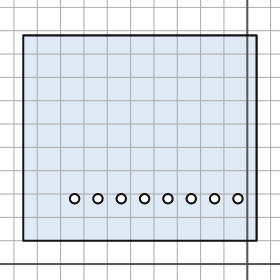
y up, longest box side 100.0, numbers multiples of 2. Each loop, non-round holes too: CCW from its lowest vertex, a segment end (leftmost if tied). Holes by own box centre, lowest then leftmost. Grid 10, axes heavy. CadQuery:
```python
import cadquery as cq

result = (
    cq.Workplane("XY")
    .moveTo(-96.0, 10.0)
    .lineTo(4.0, 10.0)
    .lineTo(4.0, 98.0)
    .lineTo(-96.0, 98.0)
    .close()
    .moveTo(-74.0, 28.0)
    .circle(2.0)
    .moveTo(-64.0, 28.0)
    .circle(2.0)
    .moveTo(-54.0, 28.0)
    .circle(2.0)
    .moveTo(-44.0, 28.0)
    .circle(2.0)
    .moveTo(-34.0, 28.0)
    .circle(2.0)
    .moveTo(-24.0, 28.0)
    .circle(2.0)
    .moveTo(-14.0, 28.0)
    .circle(2.0)
    .moveTo(-4.0, 28.0)
    .circle(2.0)
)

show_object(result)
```